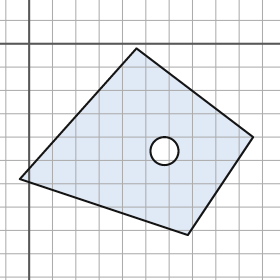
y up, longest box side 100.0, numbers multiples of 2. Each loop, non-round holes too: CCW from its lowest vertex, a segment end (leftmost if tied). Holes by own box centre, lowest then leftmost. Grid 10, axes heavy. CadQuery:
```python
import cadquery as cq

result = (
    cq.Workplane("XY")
    .moveTo(68.0, -82.0)
    .lineTo(96.0, -40.0)
    .lineTo(46.0, -2.0)
    .lineTo(-4.0, -58.0)
    .close()
    .moveTo(58.0, -46.0)
    .circle(6.0)
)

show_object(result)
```